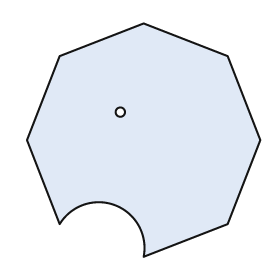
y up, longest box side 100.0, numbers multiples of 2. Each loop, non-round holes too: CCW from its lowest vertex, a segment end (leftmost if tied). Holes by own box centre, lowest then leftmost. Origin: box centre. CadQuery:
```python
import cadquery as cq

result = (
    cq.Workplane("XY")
    .moveTo(0.0, -50.0)
    .lineTo(36.0, -36.0)
    .lineTo(50.0, 0.0)
    .lineTo(36.0, 36.0)
    .lineTo(0.0, 50.0)
    .lineTo(-36.0, 36.0)
    .lineTo(-50.0, 0.0)
    .lineTo(-36.0, -36.0)
    .threePointArc((-12.0, -28.0), (0.0, -50.0))
    .close()
    .moveTo(-10.0, 12.0)
    .circle(2.0)
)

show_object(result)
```